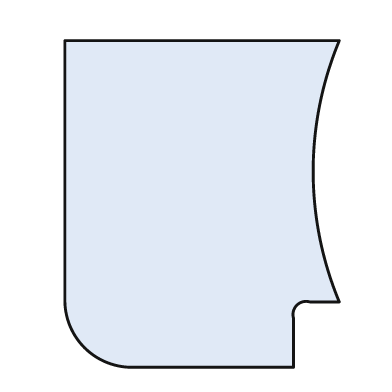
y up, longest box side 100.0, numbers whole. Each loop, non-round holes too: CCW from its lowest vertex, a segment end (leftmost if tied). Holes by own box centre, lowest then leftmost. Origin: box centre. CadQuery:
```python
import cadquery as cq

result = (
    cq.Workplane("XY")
    .moveTo(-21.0, -50.0)
    .lineTo(28.0, -50.0)
    .lineTo(28.0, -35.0)
    .threePointArc((29.0, -31.0), (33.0, -30.0))
    .lineTo(42.0, -30.0)
    .threePointArc((34.0, 10.0), (42.0, 50.0))
    .lineTo(-42.0, 50.0)
    .lineTo(-42.0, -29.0)
    .threePointArc((-36.0, -44.0), (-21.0, -50.0))
    .close()
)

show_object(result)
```